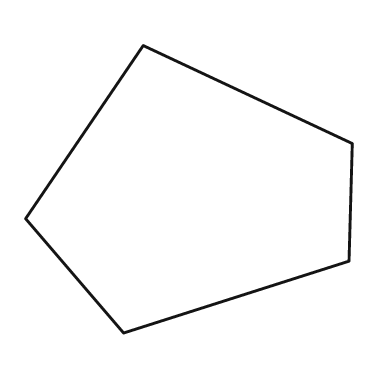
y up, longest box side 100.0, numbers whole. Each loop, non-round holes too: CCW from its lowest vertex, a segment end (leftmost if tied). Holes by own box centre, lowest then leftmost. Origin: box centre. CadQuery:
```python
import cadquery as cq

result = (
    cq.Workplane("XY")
    .moveTo(-20.0, -44.0)
    .lineTo(49.0, -22.0)
    .lineTo(50.0, 14.0)
    .lineTo(-14.0, 44.0)
    .lineTo(-50.0, -9.0)
    .close()
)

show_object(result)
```